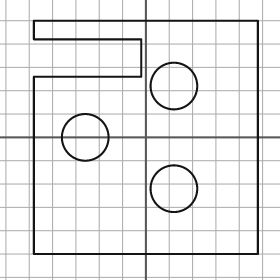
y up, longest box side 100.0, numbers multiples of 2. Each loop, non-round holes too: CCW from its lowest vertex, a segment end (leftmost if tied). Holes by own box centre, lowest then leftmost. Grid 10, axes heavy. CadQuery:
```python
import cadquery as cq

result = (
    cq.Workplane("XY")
    .moveTo(-48.0, -50.0)
    .lineTo(48.0, -50.0)
    .lineTo(48.0, 50.0)
    .lineTo(-48.0, 50.0)
    .lineTo(-48.0, 42.0)
    .lineTo(-2.0, 42.0)
    .lineTo(-2.0, 26.0)
    .lineTo(-48.0, 26.0)
    .close()
    .moveTo(12.0, -22.0)
    .circle(10.0)
    .moveTo(-26.0, 0.0)
    .circle(10.0)
    .moveTo(12.0, 22.0)
    .circle(10.0)
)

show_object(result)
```